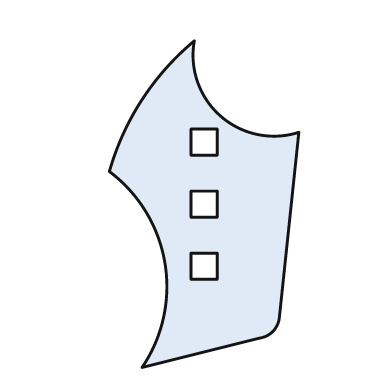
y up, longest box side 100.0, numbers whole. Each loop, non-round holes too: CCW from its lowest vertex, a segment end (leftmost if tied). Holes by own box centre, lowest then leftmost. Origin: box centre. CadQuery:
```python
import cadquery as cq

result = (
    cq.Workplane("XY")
    .moveTo(-19.0, -50.0)
    .lineTo(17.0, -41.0)
    .threePointArc((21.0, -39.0), (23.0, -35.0))
    .lineTo(29.0, 22.0)
    .threePointArc((5.0, 27.0), (-3.0, 50.0))
    .threePointArc((-19.0, 32.0), (-29.0, 10.0))
    .threePointArc((-12.0, -18.0), (-19.0, -50.0))
    .close()
    .moveTo(-4.0, -23.0)
    .lineTo(4.0, -23.0)
    .lineTo(4.0, -15.0)
    .lineTo(-4.0, -15.0)
    .close()
    .moveTo(-4.0, -4.0)
    .lineTo(4.0, -4.0)
    .lineTo(4.0, 4.0)
    .lineTo(-4.0, 4.0)
    .close()
    .moveTo(-4.0, 15.0)
    .lineTo(4.0, 15.0)
    .lineTo(4.0, 23.0)
    .lineTo(-4.0, 23.0)
    .close()
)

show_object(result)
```